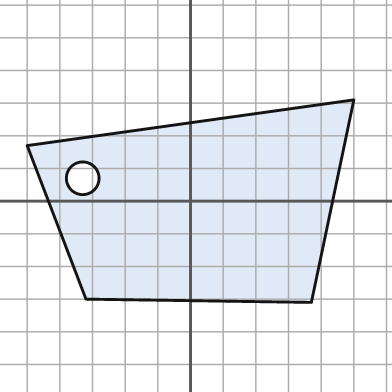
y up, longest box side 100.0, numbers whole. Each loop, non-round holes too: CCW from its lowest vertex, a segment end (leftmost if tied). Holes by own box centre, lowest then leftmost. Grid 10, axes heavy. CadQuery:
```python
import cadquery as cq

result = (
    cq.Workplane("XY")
    .moveTo(37.0, -31.0)
    .lineTo(50.0, 31.0)
    .lineTo(-50.0, 17.0)
    .lineTo(-32.0, -30.0)
    .close()
    .moveTo(-33.0, 7.0)
    .circle(5.0)
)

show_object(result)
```